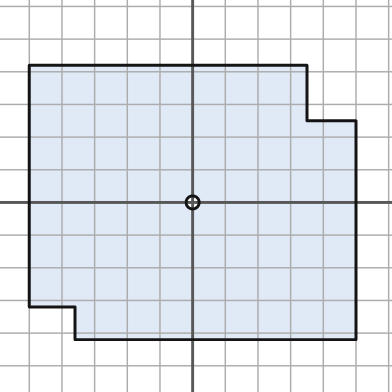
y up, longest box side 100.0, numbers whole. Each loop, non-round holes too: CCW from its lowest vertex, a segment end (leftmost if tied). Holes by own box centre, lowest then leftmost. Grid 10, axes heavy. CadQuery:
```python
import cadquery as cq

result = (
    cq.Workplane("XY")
    .moveTo(-36.0, -42.0)
    .lineTo(50.0, -42.0)
    .lineTo(50.0, 25.0)
    .lineTo(35.0, 25.0)
    .lineTo(35.0, 42.0)
    .lineTo(-50.0, 42.0)
    .lineTo(-50.0, -32.0)
    .lineTo(-36.0, -32.0)
    .close()
    .moveTo(0.0, 0.0)
    .circle(2.0)
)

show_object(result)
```